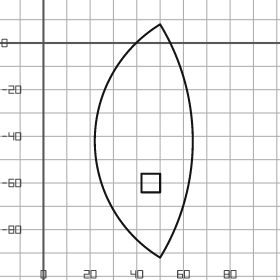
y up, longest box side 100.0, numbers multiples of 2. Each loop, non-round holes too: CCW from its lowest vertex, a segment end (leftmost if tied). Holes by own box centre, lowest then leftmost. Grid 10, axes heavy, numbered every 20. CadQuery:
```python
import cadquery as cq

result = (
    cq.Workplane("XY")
    .moveTo(50.0, -92.0)
    .threePointArc((64.0, -42.0), (50.0, 8.0))
    .threePointArc((22.0, -42.0), (50.0, -92.0))
    .close()
    .moveTo(42.0, -64.0)
    .lineTo(50.0, -64.0)
    .lineTo(50.0, -56.0)
    .lineTo(42.0, -56.0)
    .close()
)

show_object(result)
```